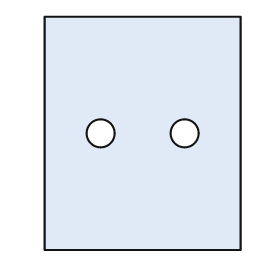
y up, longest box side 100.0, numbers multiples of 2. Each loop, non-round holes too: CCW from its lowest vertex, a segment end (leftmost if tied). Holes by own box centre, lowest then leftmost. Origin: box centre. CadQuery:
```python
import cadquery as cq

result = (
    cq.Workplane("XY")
    .moveTo(-42.0, -50.0)
    .lineTo(42.0, -50.0)
    .lineTo(42.0, 50.0)
    .lineTo(-42.0, 50.0)
    .close()
    .moveTo(-18.0, 0.0)
    .circle(6.0)
    .moveTo(18.0, 0.0)
    .circle(6.0)
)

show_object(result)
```